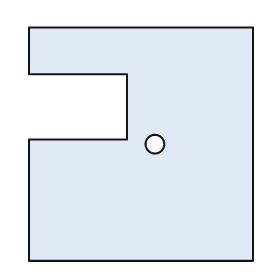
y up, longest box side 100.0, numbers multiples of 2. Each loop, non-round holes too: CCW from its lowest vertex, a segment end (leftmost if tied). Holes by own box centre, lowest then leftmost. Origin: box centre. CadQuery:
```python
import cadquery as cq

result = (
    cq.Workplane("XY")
    .moveTo(-48.0, -50.0)
    .lineTo(48.0, -50.0)
    .lineTo(48.0, 50.0)
    .lineTo(-48.0, 50.0)
    .lineTo(-48.0, 30.0)
    .lineTo(-6.0, 30.0)
    .lineTo(-6.0, 2.0)
    .lineTo(-48.0, 2.0)
    .close()
    .moveTo(6.0, 0.0)
    .circle(4.0)
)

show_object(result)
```